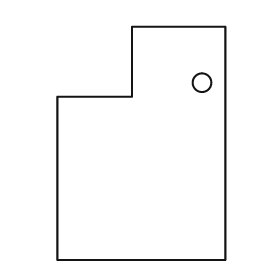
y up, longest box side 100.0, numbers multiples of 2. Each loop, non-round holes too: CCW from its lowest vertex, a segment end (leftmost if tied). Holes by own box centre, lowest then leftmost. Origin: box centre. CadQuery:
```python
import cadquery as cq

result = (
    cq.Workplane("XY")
    .moveTo(-36.0, -50.0)
    .lineTo(36.0, -50.0)
    .lineTo(36.0, 50.0)
    .lineTo(-4.0, 50.0)
    .lineTo(-4.0, 20.0)
    .lineTo(-36.0, 20.0)
    .close()
    .moveTo(26.0, 26.0)
    .circle(4.0)
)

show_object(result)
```